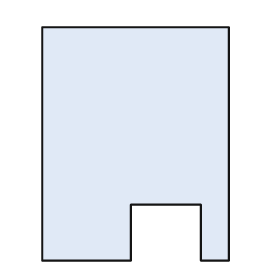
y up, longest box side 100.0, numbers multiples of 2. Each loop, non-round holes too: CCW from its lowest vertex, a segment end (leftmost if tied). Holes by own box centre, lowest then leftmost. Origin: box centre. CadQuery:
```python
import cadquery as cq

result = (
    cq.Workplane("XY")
    .moveTo(-40.0, -50.0)
    .lineTo(-2.0, -50.0)
    .lineTo(-2.0, -26.0)
    .lineTo(28.0, -26.0)
    .lineTo(28.0, -50.0)
    .lineTo(40.0, -50.0)
    .lineTo(40.0, 50.0)
    .lineTo(-40.0, 50.0)
    .close()
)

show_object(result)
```